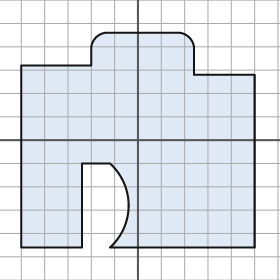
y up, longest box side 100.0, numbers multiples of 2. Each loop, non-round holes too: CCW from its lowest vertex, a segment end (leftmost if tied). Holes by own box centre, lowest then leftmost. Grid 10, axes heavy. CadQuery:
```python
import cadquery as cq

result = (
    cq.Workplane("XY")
    .moveTo(-50.0, -46.0)
    .lineTo(-24.0, -46.0)
    .lineTo(-24.0, -10.0)
    .lineTo(-12.0, -10.0)
    .threePointArc((-4.0, -28.0), (-12.0, -46.0))
    .lineTo(50.0, -46.0)
    .lineTo(50.0, 28.0)
    .lineTo(24.0, 28.0)
    .lineTo(24.0, 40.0)
    .threePointArc((22.0, 44.0), (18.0, 46.0))
    .lineTo(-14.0, 46.0)
    .threePointArc((-18.0, 44.0), (-20.0, 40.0))
    .lineTo(-20.0, 32.0)
    .lineTo(-50.0, 32.0)
    .close()
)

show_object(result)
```